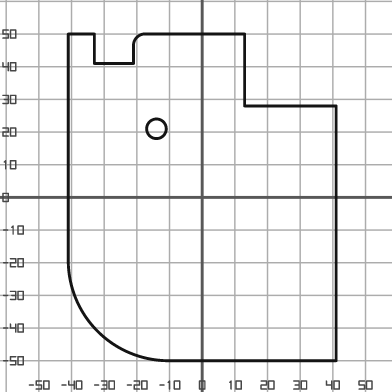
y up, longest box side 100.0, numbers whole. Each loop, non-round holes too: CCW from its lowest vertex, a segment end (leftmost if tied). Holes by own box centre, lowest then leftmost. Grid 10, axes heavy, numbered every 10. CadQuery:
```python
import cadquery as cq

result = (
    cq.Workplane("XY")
    .moveTo(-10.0, -50.0)
    .lineTo(41.0, -50.0)
    .lineTo(41.0, 28.0)
    .lineTo(13.0, 28.0)
    .lineTo(13.0, 50.0)
    .lineTo(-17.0, 50.0)
    .threePointArc((-20.0, 49.0), (-21.0, 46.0))
    .lineTo(-21.0, 41.0)
    .lineTo(-33.0, 41.0)
    .lineTo(-33.0, 50.0)
    .lineTo(-41.0, 50.0)
    .lineTo(-41.0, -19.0)
    .threePointArc((-32.0, -41.0), (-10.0, -50.0))
    .close()
    .moveTo(-14.0, 21.0)
    .circle(3.0)
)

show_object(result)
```